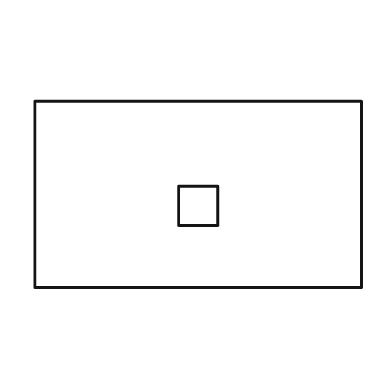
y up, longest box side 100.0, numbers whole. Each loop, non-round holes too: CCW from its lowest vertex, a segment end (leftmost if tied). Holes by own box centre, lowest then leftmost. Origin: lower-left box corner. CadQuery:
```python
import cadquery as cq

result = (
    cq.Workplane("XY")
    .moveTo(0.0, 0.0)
    .lineTo(100.0, 0.0)
    .lineTo(100.0, 57.0)
    .lineTo(0.0, 57.0)
    .close()
    .moveTo(44.0, 19.0)
    .lineTo(56.0, 19.0)
    .lineTo(56.0, 31.0)
    .lineTo(44.0, 31.0)
    .close()
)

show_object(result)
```